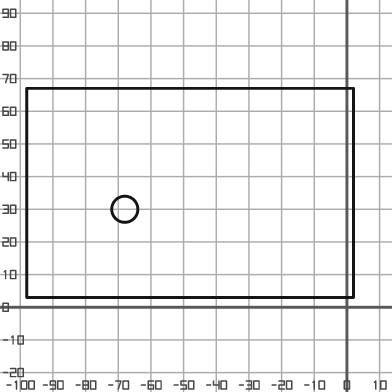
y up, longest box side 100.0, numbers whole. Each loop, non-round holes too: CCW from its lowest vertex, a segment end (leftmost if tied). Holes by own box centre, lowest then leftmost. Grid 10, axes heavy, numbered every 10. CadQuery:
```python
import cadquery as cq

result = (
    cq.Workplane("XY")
    .moveTo(-98.0, 3.0)
    .lineTo(2.0, 3.0)
    .lineTo(2.0, 67.0)
    .lineTo(-98.0, 67.0)
    .close()
    .moveTo(-68.0, 30.0)
    .circle(4.0)
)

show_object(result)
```